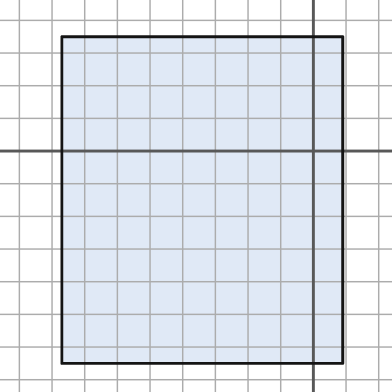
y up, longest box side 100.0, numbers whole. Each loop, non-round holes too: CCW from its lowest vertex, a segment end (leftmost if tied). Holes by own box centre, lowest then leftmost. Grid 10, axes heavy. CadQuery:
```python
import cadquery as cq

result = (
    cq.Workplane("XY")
    .moveTo(-77.0, -65.0)
    .lineTo(9.0, -65.0)
    .lineTo(9.0, 35.0)
    .lineTo(-77.0, 35.0)
    .close()
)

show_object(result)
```